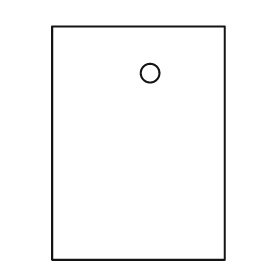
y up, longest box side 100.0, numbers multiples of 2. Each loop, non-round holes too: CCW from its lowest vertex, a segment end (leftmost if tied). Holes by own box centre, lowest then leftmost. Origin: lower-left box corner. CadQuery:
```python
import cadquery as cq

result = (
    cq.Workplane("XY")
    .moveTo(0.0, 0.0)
    .lineTo(74.0, 0.0)
    .lineTo(74.0, 100.0)
    .lineTo(0.0, 100.0)
    .close()
    .moveTo(42.0, 80.0)
    .circle(4.0)
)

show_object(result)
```